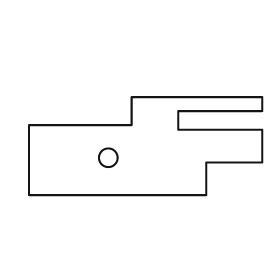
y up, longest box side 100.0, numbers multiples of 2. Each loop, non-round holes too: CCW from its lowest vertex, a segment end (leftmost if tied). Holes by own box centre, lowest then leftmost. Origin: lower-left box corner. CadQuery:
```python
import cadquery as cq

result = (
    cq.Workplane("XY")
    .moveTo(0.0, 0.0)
    .lineTo(76.0, 0.0)
    .lineTo(76.0, 14.0)
    .lineTo(100.0, 14.0)
    .lineTo(100.0, 28.0)
    .lineTo(64.0, 28.0)
    .lineTo(64.0, 36.0)
    .lineTo(100.0, 36.0)
    .lineTo(100.0, 42.0)
    .lineTo(44.0, 42.0)
    .lineTo(44.0, 30.0)
    .lineTo(0.0, 30.0)
    .close()
    .moveTo(34.0, 16.0)
    .circle(4.0)
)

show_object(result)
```